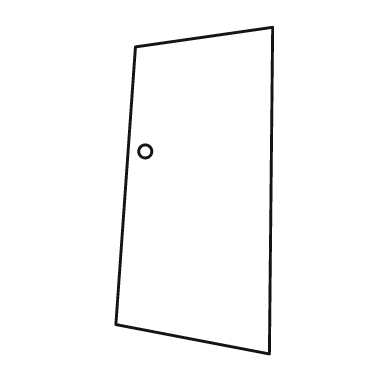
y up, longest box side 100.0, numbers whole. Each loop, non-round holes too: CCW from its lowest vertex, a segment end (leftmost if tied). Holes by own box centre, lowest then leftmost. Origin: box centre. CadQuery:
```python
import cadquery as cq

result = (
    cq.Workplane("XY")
    .moveTo(23.0, -50.0)
    .lineTo(24.0, 50.0)
    .lineTo(-18.0, 44.0)
    .lineTo(-24.0, -41.0)
    .close()
    .moveTo(-15.0, 12.0)
    .circle(2.0)
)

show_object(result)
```